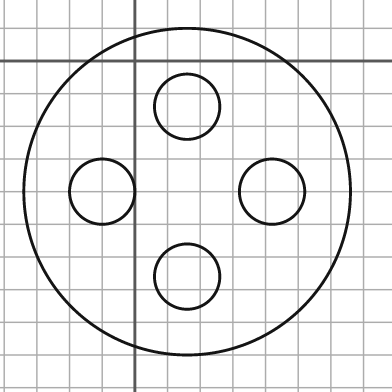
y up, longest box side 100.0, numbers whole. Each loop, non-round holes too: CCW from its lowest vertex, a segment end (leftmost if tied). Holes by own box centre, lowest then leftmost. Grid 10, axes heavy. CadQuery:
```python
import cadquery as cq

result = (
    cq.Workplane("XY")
    .moveTo(16.0, -40.0)
    .circle(50.0)
    .moveTo(16.0, -66.0)
    .circle(10.0)
    .moveTo(-10.0, -40.0)
    .circle(10.0)
    .moveTo(42.0, -40.0)
    .circle(10.0)
    .moveTo(16.0, -14.0)
    .circle(10.0)
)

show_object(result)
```